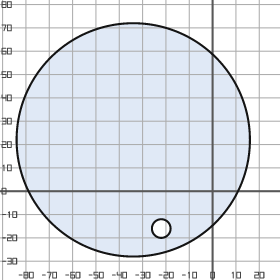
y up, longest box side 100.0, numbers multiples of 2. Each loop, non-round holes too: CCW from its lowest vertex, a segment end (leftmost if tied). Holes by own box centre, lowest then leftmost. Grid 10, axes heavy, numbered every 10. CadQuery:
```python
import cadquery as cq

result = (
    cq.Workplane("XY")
    .moveTo(-34.0, 22.0)
    .circle(50.0)
    .moveTo(-22.0, -16.0)
    .circle(4.0)
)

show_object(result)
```